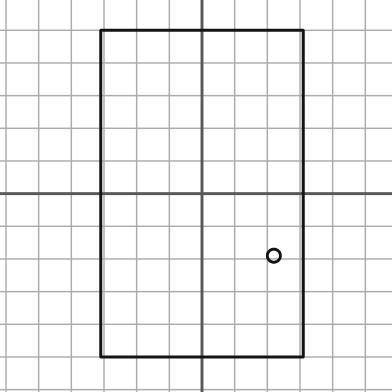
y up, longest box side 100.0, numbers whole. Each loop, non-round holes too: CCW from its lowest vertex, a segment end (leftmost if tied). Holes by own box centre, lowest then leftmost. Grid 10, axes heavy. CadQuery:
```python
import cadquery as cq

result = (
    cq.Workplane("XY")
    .moveTo(-31.0, -50.0)
    .lineTo(31.0, -50.0)
    .lineTo(31.0, 50.0)
    .lineTo(-31.0, 50.0)
    .close()
    .moveTo(22.0, -19.0)
    .circle(2.0)
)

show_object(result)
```